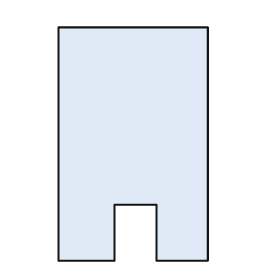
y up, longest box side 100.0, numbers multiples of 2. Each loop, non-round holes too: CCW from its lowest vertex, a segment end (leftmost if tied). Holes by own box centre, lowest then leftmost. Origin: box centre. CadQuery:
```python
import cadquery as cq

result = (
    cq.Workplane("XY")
    .moveTo(-32.0, -50.0)
    .lineTo(-8.0, -50.0)
    .lineTo(-8.0, -26.0)
    .lineTo(10.0, -26.0)
    .lineTo(10.0, -50.0)
    .lineTo(32.0, -50.0)
    .lineTo(32.0, 50.0)
    .lineTo(-32.0, 50.0)
    .close()
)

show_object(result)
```